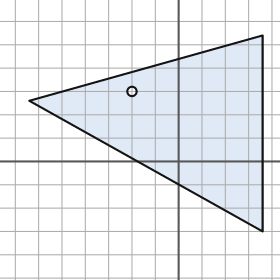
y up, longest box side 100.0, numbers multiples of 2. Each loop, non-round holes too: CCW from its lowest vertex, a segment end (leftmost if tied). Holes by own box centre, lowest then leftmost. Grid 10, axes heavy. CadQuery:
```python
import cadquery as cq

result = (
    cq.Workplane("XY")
    .moveTo(36.0, -30.0)
    .lineTo(36.0, 54.0)
    .lineTo(-64.0, 26.0)
    .close()
    .moveTo(-20.0, 30.0)
    .circle(2.0)
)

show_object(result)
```